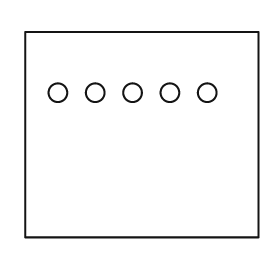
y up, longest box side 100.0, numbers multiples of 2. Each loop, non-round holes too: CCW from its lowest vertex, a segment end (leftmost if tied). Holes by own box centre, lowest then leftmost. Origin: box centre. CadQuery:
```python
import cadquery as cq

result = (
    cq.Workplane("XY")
    .moveTo(-50.0, -44.0)
    .lineTo(50.0, -44.0)
    .lineTo(50.0, 44.0)
    .lineTo(-50.0, 44.0)
    .close()
    .moveTo(-36.0, 18.0)
    .circle(4.0)
    .moveTo(-20.0, 18.0)
    .circle(4.0)
    .moveTo(-4.0, 18.0)
    .circle(4.0)
    .moveTo(12.0, 18.0)
    .circle(4.0)
    .moveTo(28.0, 18.0)
    .circle(4.0)
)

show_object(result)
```